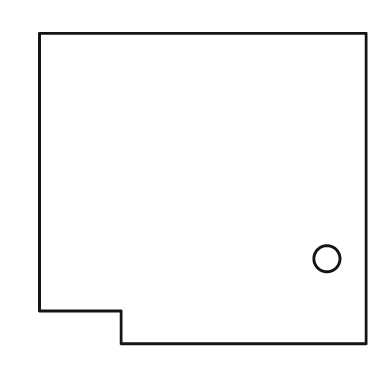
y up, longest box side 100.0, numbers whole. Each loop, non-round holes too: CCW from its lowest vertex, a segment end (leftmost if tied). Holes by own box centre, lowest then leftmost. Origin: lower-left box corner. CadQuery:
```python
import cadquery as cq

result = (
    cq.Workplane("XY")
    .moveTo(25.0, 0.0)
    .lineTo(100.0, 0.0)
    .lineTo(100.0, 95.0)
    .lineTo(0.0, 95.0)
    .lineTo(0.0, 10.0)
    .lineTo(25.0, 10.0)
    .close()
    .moveTo(88.0, 26.0)
    .circle(4.0)
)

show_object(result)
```